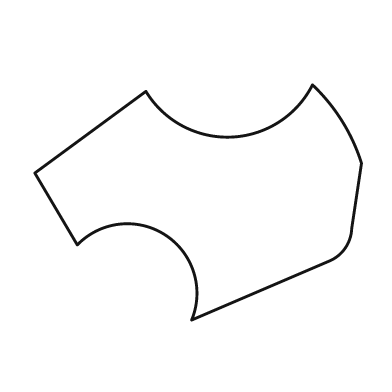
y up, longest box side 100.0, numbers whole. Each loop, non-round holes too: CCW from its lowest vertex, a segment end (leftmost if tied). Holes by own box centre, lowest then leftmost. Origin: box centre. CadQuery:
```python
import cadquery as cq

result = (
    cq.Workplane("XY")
    .moveTo(-2.0, -36.0)
    .lineTo(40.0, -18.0)
    .threePointArc((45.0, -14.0), (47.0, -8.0))
    .lineTo(50.0, 12.0)
    .threePointArc((44.0, 25.0), (35.0, 36.0))
    .threePointArc((10.0, 20.0), (-16.0, 34.0))
    .lineTo(-50.0, 9.0)
    .lineTo(-37.0, -13.0)
    .threePointArc((-10.0, -10.0), (-2.0, -36.0))
    .close()
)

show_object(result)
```